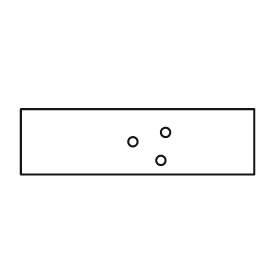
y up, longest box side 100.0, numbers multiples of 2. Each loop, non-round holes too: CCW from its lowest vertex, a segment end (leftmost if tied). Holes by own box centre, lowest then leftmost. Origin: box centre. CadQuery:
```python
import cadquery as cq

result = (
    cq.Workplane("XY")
    .moveTo(-50.0, -14.0)
    .lineTo(50.0, -14.0)
    .lineTo(50.0, 14.0)
    .lineTo(-50.0, 14.0)
    .close()
    .moveTo(10.0, -8.0)
    .circle(2.0)
    .moveTo(-2.0, 0.0)
    .circle(2.0)
    .moveTo(12.0, 4.0)
    .circle(2.0)
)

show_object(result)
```